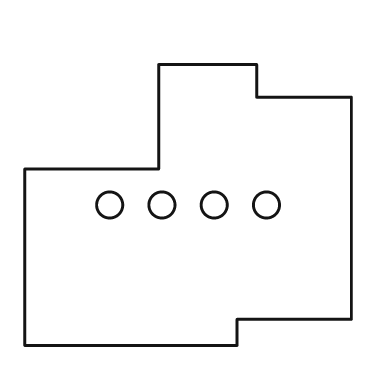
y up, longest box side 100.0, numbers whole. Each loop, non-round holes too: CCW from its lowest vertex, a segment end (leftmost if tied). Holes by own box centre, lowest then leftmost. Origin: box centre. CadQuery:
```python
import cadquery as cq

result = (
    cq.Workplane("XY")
    .moveTo(-50.0, -43.0)
    .lineTo(15.0, -43.0)
    .lineTo(15.0, -35.0)
    .lineTo(50.0, -35.0)
    .lineTo(50.0, 33.0)
    .lineTo(21.0, 33.0)
    .lineTo(21.0, 43.0)
    .lineTo(-9.0, 43.0)
    .lineTo(-9.0, 11.0)
    .lineTo(-50.0, 11.0)
    .close()
    .moveTo(-24.0, 0.0)
    .circle(4.0)
    .moveTo(-8.0, 0.0)
    .circle(4.0)
    .moveTo(8.0, 0.0)
    .circle(4.0)
    .moveTo(24.0, 0.0)
    .circle(4.0)
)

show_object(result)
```